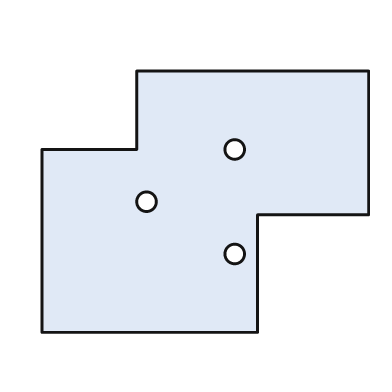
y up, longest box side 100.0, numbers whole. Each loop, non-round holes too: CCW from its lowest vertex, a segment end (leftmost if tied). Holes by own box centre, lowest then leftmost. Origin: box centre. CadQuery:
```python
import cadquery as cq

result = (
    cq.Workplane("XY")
    .moveTo(-50.0, -40.0)
    .lineTo(16.0, -40.0)
    .lineTo(16.0, -4.0)
    .lineTo(50.0, -4.0)
    .lineTo(50.0, 40.0)
    .lineTo(-21.0, 40.0)
    .lineTo(-21.0, 16.0)
    .lineTo(-50.0, 16.0)
    .close()
    .moveTo(9.0, -16.0)
    .circle(3.0)
    .moveTo(-18.0, 0.0)
    .circle(3.0)
    .moveTo(9.0, 16.0)
    .circle(3.0)
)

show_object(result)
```